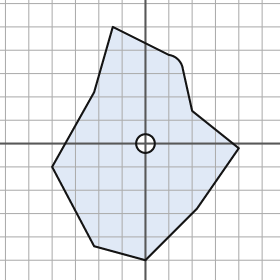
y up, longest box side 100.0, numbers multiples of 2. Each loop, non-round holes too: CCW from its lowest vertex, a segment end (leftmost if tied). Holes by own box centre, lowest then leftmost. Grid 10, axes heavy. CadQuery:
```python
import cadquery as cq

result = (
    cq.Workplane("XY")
    .moveTo(0.0, -50.0)
    .lineTo(22.0, -28.0)
    .lineTo(40.0, -2.0)
    .lineTo(20.0, 14.0)
    .lineTo(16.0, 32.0)
    .threePointArc((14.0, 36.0), (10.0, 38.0))
    .lineTo(-14.0, 50.0)
    .lineTo(-22.0, 22.0)
    .lineTo(-40.0, -10.0)
    .lineTo(-22.0, -44.0)
    .close()
    .moveTo(0.0, 0.0)
    .circle(4.0)
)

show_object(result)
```